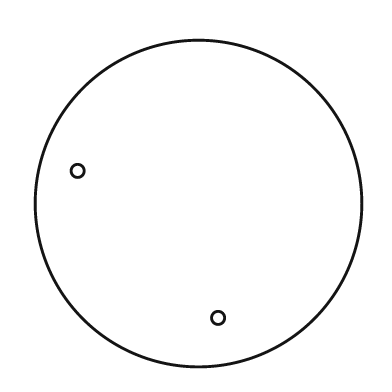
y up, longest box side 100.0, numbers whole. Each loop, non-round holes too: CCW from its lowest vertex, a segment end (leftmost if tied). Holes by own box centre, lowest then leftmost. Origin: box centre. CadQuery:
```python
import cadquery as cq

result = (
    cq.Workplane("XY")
    .moveTo(0.0, 0.0)
    .circle(50.0)
    .moveTo(6.0, -35.0)
    .circle(2.0)
    .moveTo(-37.0, 10.0)
    .circle(2.0)
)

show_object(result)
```